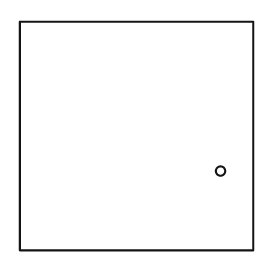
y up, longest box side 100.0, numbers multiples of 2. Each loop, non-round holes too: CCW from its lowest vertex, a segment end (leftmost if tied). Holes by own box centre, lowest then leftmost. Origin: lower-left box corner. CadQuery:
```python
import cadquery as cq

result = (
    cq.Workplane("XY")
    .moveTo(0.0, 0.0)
    .lineTo(100.0, 0.0)
    .lineTo(100.0, 98.0)
    .lineTo(0.0, 98.0)
    .close()
    .moveTo(86.0, 34.0)
    .circle(2.0)
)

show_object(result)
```